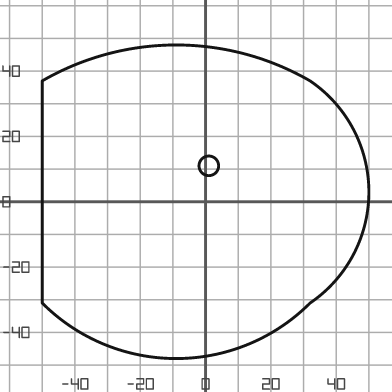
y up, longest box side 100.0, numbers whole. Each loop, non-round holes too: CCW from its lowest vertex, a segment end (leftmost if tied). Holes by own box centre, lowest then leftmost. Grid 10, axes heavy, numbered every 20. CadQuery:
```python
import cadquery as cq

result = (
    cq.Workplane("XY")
    .moveTo(-50.0, -31.0)
    .threePointArc((-9.0, -48.0), (32.0, -31.0))
    .threePointArc((50.0, 3.0), (32.0, 37.0))
    .threePointArc((-9.0, 48.0), (-50.0, 37.0))
    .close()
    .moveTo(1.0, 11.0)
    .circle(3.0)
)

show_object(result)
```